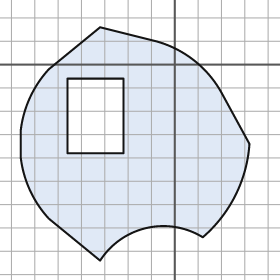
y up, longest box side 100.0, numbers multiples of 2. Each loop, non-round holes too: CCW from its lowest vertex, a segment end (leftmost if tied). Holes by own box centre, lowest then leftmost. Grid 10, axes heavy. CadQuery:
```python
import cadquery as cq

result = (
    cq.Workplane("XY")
    .moveTo(-32.0, -84.0)
    .threePointArc((-12.0, -70.0), (12.0, -74.0))
    .threePointArc((26.0, -56.0), (32.0, -34.0))
    .lineTo(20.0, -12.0)
    .threePointArc((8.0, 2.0), (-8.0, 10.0))
    .lineTo(-32.0, 16.0)
    .lineTo(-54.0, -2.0)
    .threePointArc((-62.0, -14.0), (-66.0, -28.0))
    .lineTo(-66.0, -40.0)
    .threePointArc((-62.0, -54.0), (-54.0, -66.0))
    .close()
    .moveTo(-46.0, -38.0)
    .lineTo(-22.0, -38.0)
    .lineTo(-22.0, -6.0)
    .lineTo(-46.0, -6.0)
    .close()
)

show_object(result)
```